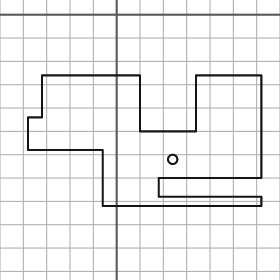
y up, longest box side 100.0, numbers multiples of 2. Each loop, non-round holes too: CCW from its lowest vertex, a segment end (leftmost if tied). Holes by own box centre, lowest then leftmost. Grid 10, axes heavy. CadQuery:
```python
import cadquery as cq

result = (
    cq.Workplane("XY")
    .moveTo(-6.0, -82.0)
    .lineTo(62.0, -82.0)
    .lineTo(62.0, -78.0)
    .lineTo(18.0, -78.0)
    .lineTo(18.0, -70.0)
    .lineTo(62.0, -70.0)
    .lineTo(62.0, -26.0)
    .lineTo(34.0, -26.0)
    .lineTo(34.0, -50.0)
    .lineTo(10.0, -50.0)
    .lineTo(10.0, -26.0)
    .lineTo(-32.0, -26.0)
    .lineTo(-32.0, -44.0)
    .lineTo(-38.0, -44.0)
    .lineTo(-38.0, -58.0)
    .lineTo(-6.0, -58.0)
    .close()
    .moveTo(24.0, -62.0)
    .circle(2.0)
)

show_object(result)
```